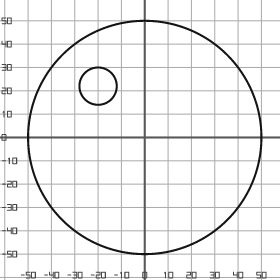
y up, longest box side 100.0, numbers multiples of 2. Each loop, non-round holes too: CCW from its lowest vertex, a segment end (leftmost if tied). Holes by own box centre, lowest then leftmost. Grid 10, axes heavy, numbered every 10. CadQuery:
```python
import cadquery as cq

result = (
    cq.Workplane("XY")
    .moveTo(0.0, 0.0)
    .circle(50.0)
    .moveTo(-20.0, 22.0)
    .circle(8.0)
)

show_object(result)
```